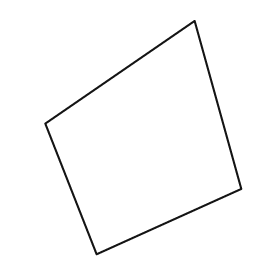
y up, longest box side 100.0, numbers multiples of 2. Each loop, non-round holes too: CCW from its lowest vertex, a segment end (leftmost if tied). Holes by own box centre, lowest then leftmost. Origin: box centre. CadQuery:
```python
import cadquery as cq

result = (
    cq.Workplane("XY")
    .moveTo(-20.0, -50.0)
    .lineTo(42.0, -22.0)
    .lineTo(22.0, 50.0)
    .lineTo(-42.0, 6.0)
    .close()
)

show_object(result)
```